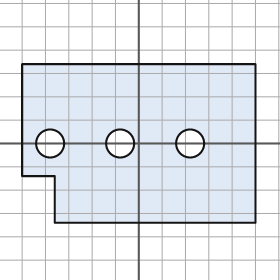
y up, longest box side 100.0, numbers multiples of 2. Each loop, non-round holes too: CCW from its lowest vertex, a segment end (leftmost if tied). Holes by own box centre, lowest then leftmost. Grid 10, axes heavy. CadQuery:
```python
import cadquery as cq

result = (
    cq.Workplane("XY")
    .moveTo(-36.0, -34.0)
    .lineTo(50.0, -34.0)
    .lineTo(50.0, 34.0)
    .lineTo(-50.0, 34.0)
    .lineTo(-50.0, -14.0)
    .lineTo(-36.0, -14.0)
    .close()
    .moveTo(-38.0, 0.0)
    .circle(6.0)
    .moveTo(-8.0, 0.0)
    .circle(6.0)
    .moveTo(22.0, 0.0)
    .circle(6.0)
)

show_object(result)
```